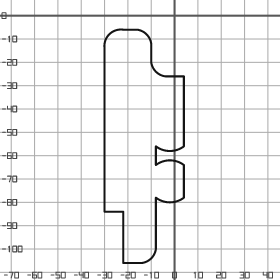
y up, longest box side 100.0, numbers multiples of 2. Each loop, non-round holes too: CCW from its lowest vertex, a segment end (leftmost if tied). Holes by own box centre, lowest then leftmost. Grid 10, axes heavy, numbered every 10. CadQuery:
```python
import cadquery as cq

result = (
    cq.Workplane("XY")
    .moveTo(-22.0, -106.0)
    .lineTo(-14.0, -106.0)
    .threePointArc((-10.0, -104.0), (-8.0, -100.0))
    .lineTo(-8.0, -78.0)
    .threePointArc((-2.0, -80.0), (4.0, -78.0))
    .lineTo(4.0, -64.0)
    .threePointArc((-2.0, -62.0), (-8.0, -64.0))
    .lineTo(-8.0, -56.0)
    .threePointArc((-2.0, -58.0), (4.0, -56.0))
    .lineTo(4.0, -26.0)
    .lineTo(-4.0, -26.0)
    .threePointArc((-8.0, -24.0), (-10.0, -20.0))
    .lineTo(-10.0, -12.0)
    .threePointArc((-12.0, -8.0), (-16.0, -6.0))
    .lineTo(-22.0, -6.0)
    .threePointArc((-28.0, -8.0), (-30.0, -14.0))
    .lineTo(-30.0, -84.0)
    .lineTo(-22.0, -84.0)
    .close()
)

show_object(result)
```